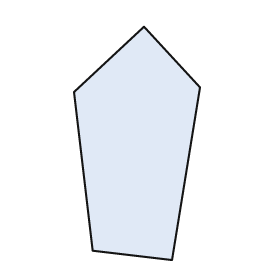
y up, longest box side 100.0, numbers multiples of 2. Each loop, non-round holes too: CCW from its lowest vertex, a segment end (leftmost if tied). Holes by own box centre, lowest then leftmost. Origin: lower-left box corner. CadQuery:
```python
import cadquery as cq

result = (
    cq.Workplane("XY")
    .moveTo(42.0, 0.0)
    .lineTo(54.0, 74.0)
    .lineTo(30.0, 100.0)
    .lineTo(0.0, 72.0)
    .lineTo(8.0, 4.0)
    .close()
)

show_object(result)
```